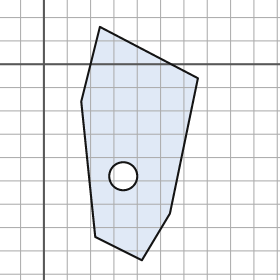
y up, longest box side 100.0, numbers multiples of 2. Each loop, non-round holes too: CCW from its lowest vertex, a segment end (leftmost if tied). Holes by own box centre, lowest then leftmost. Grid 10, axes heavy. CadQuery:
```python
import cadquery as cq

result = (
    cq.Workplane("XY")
    .moveTo(42.0, -84.0)
    .lineTo(54.0, -64.0)
    .lineTo(66.0, -6.0)
    .lineTo(24.0, 16.0)
    .lineTo(16.0, -16.0)
    .lineTo(22.0, -74.0)
    .close()
    .moveTo(34.0, -48.0)
    .circle(6.0)
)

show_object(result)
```